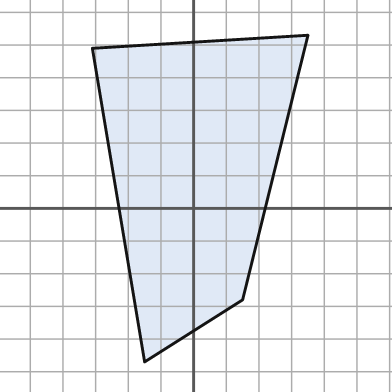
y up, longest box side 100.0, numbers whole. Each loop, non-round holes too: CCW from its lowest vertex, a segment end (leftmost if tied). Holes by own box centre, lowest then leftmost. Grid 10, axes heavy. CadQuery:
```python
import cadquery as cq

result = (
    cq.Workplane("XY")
    .moveTo(-15.0, -47.0)
    .lineTo(15.0, -28.0)
    .lineTo(35.0, 53.0)
    .lineTo(-31.0, 49.0)
    .close()
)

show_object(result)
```